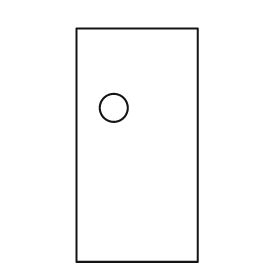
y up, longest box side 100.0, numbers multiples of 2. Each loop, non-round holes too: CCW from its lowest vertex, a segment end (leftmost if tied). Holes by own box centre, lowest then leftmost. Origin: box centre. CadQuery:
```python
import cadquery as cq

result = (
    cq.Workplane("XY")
    .moveTo(-26.0, -50.0)
    .lineTo(26.0, -50.0)
    .lineTo(26.0, 50.0)
    .lineTo(-26.0, 50.0)
    .close()
    .moveTo(-10.0, 16.0)
    .circle(6.0)
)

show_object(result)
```